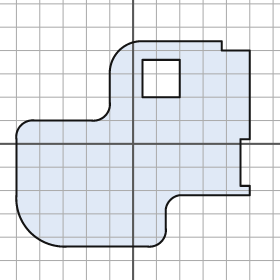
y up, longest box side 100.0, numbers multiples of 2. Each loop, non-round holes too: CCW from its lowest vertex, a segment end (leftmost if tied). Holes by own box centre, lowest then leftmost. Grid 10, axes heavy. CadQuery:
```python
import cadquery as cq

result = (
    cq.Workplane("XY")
    .moveTo(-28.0, -44.0)
    .lineTo(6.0, -44.0)
    .threePointArc((12.0, -42.0), (14.0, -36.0))
    .lineTo(14.0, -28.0)
    .threePointArc((16.0, -24.0), (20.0, -22.0))
    .lineTo(50.0, -22.0)
    .lineTo(50.0, -18.0)
    .lineTo(46.0, -18.0)
    .lineTo(46.0, 2.0)
    .lineTo(50.0, 2.0)
    .lineTo(50.0, 40.0)
    .lineTo(38.0, 40.0)
    .lineTo(38.0, 44.0)
    .lineTo(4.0, 44.0)
    .threePointArc((-6.0, 40.0), (-10.0, 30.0))
    .lineTo(-10.0, 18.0)
    .threePointArc((-12.0, 12.0), (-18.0, 10.0))
    .lineTo(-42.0, 10.0)
    .threePointArc((-48.0, 8.0), (-50.0, 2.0))
    .lineTo(-50.0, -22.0)
    .threePointArc((-44.0, -38.0), (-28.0, -44.0))
    .close()
    .moveTo(4.0, 20.0)
    .lineTo(20.0, 20.0)
    .lineTo(20.0, 36.0)
    .lineTo(4.0, 36.0)
    .close()
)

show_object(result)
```